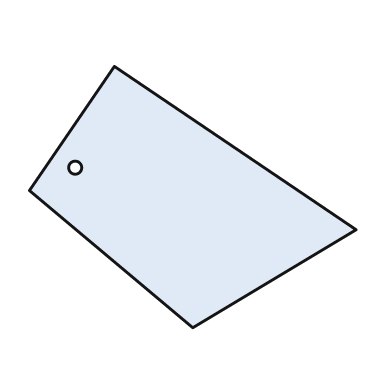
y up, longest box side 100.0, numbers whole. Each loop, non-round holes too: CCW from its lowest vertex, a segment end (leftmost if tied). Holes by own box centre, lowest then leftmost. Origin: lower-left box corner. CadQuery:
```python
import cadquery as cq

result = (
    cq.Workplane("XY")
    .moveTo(50.0, 0.0)
    .lineTo(100.0, 30.0)
    .lineTo(26.0, 80.0)
    .lineTo(0.0, 42.0)
    .close()
    .moveTo(14.0, 49.0)
    .circle(2.0)
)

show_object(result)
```